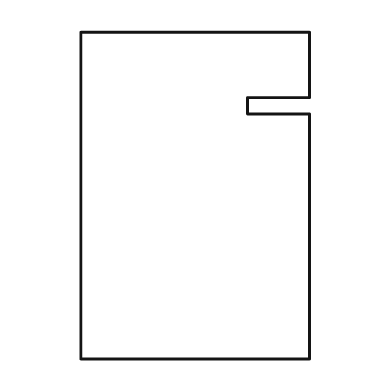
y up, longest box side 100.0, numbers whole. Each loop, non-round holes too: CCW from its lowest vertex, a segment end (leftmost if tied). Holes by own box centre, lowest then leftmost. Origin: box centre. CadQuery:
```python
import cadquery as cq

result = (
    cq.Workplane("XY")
    .moveTo(-35.0, -50.0)
    .lineTo(35.0, -50.0)
    .lineTo(35.0, 25.0)
    .lineTo(16.0, 25.0)
    .lineTo(16.0, 30.0)
    .lineTo(35.0, 30.0)
    .lineTo(35.0, 50.0)
    .lineTo(-35.0, 50.0)
    .close()
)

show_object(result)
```